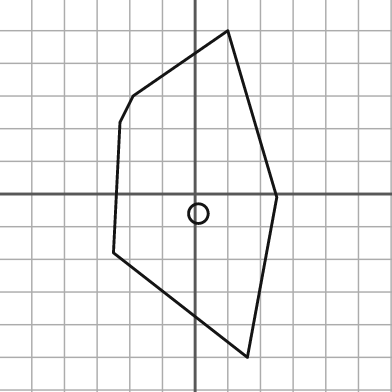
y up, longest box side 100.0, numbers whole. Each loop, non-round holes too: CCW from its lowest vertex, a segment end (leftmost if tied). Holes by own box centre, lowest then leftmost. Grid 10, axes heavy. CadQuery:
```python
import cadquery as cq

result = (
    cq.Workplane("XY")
    .moveTo(16.0, -50.0)
    .lineTo(25.0, -1.0)
    .lineTo(10.0, 50.0)
    .lineTo(-19.0, 30.0)
    .lineTo(-23.0, 22.0)
    .lineTo(-25.0, -18.0)
    .close()
    .moveTo(1.0, -6.0)
    .circle(3.0)
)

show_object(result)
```